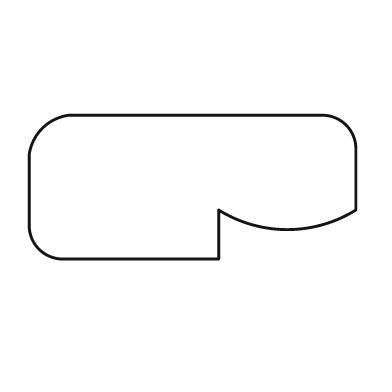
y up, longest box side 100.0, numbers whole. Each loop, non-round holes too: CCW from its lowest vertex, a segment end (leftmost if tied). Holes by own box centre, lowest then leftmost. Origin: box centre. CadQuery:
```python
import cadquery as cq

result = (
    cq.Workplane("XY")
    .moveTo(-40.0, -22.0)
    .lineTo(8.0, -22.0)
    .lineTo(8.0, -7.0)
    .threePointArc((29.0, -13.0), (50.0, -7.0))
    .lineTo(50.0, 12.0)
    .threePointArc((47.0, 19.0), (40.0, 22.0))
    .lineTo(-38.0, 22.0)
    .threePointArc((-46.0, 18.0), (-50.0, 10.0))
    .lineTo(-50.0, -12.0)
    .threePointArc((-47.0, -19.0), (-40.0, -22.0))
    .close()
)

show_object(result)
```